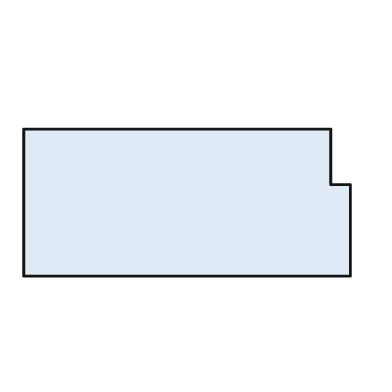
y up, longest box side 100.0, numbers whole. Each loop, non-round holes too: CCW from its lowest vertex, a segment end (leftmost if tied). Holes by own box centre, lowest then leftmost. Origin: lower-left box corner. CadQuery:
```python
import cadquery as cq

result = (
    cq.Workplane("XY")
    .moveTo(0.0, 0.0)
    .lineTo(100.0, 0.0)
    .lineTo(100.0, 28.0)
    .lineTo(94.0, 28.0)
    .lineTo(94.0, 45.0)
    .lineTo(0.0, 45.0)
    .close()
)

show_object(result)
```